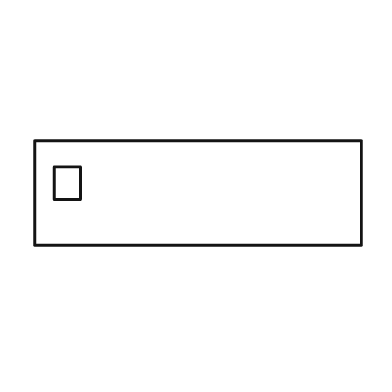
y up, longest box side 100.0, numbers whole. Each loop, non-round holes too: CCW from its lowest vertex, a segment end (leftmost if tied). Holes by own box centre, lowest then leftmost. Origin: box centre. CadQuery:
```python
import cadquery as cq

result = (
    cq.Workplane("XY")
    .moveTo(-50.0, -16.0)
    .lineTo(50.0, -16.0)
    .lineTo(50.0, 16.0)
    .lineTo(-50.0, 16.0)
    .close()
    .moveTo(-44.0, -2.0)
    .lineTo(-36.0, -2.0)
    .lineTo(-36.0, 8.0)
    .lineTo(-44.0, 8.0)
    .close()
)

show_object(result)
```